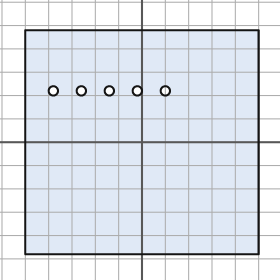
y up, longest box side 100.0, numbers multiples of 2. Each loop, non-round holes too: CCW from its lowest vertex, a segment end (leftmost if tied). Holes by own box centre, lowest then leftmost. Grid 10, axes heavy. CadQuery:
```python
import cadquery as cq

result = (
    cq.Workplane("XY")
    .moveTo(-50.0, -48.0)
    .lineTo(50.0, -48.0)
    .lineTo(50.0, 48.0)
    .lineTo(-50.0, 48.0)
    .close()
    .moveTo(-38.0, 22.0)
    .circle(2.0)
    .moveTo(-26.0, 22.0)
    .circle(2.0)
    .moveTo(-14.0, 22.0)
    .circle(2.0)
    .moveTo(-2.0, 22.0)
    .circle(2.0)
    .moveTo(10.0, 22.0)
    .circle(2.0)
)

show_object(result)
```